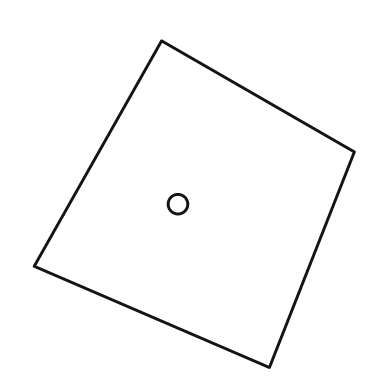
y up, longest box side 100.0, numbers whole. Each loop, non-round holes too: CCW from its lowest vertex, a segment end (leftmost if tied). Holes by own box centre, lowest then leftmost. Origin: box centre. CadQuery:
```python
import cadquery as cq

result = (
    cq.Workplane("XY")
    .moveTo(23.0, -50.0)
    .lineTo(49.0, 16.0)
    .lineTo(-10.0, 50.0)
    .lineTo(-49.0, -19.0)
    .close()
    .moveTo(-5.0, 0.0)
    .circle(3.0)
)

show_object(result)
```